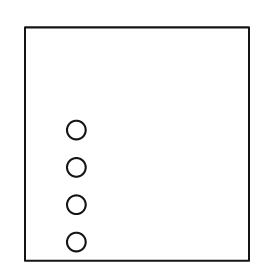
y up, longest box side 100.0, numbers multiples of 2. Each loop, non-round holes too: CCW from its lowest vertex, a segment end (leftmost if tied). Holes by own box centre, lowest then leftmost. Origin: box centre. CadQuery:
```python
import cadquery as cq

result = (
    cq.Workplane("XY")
    .moveTo(-48.0, -50.0)
    .lineTo(48.0, -50.0)
    .lineTo(48.0, 50.0)
    .lineTo(-48.0, 50.0)
    .close()
    .moveTo(-26.0, -42.0)
    .circle(4.0)
    .moveTo(-26.0, -26.0)
    .circle(4.0)
    .moveTo(-26.0, -10.0)
    .circle(4.0)
    .moveTo(-26.0, 6.0)
    .circle(4.0)
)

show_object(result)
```